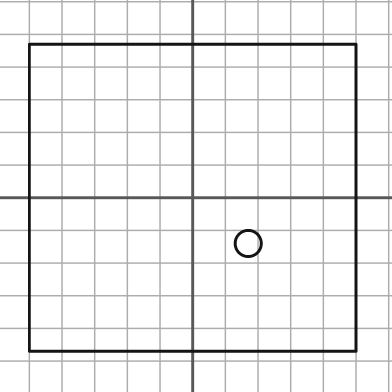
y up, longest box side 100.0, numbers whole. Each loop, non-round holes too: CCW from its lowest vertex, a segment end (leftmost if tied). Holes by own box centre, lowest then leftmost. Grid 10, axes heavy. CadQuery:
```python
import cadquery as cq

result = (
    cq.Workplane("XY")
    .moveTo(-50.0, -47.0)
    .lineTo(50.0, -47.0)
    .lineTo(50.0, 47.0)
    .lineTo(-50.0, 47.0)
    .close()
    .moveTo(17.0, -14.0)
    .circle(4.0)
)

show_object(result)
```